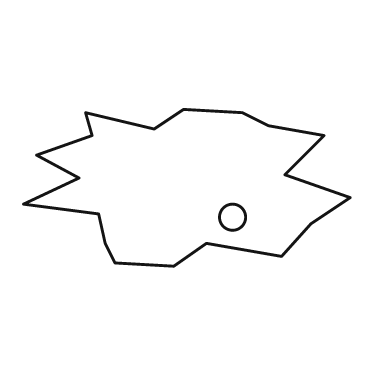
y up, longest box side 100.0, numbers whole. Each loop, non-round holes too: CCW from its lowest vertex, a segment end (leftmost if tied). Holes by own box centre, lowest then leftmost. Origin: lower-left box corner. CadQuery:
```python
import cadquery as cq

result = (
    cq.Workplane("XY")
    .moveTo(46.0, 0.0)
    .lineTo(56.0, 7.0)
    .lineTo(79.0, 3.0)
    .lineTo(88.0, 13.0)
    .lineTo(100.0, 21.0)
    .lineTo(80.0, 28.0)
    .lineTo(92.0, 40.0)
    .lineTo(75.0, 43.0)
    .lineTo(67.0, 47.0)
    .lineTo(49.0, 48.0)
    .lineTo(40.0, 42.0)
    .lineTo(19.0, 47.0)
    .lineTo(21.0, 40.0)
    .lineTo(4.0, 34.0)
    .lineTo(17.0, 27.0)
    .lineTo(0.0, 19.0)
    .lineTo(23.0, 16.0)
    .lineTo(25.0, 7.0)
    .lineTo(28.0, 1.0)
    .close()
    .moveTo(64.0, 15.0)
    .circle(4.0)
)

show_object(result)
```